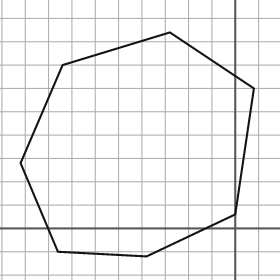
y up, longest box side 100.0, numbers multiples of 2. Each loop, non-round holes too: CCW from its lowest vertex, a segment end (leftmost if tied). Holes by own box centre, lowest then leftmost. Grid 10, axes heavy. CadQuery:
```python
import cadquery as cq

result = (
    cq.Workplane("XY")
    .moveTo(-38.0, -12.0)
    .lineTo(0.0, 6.0)
    .lineTo(8.0, 60.0)
    .lineTo(-28.0, 84.0)
    .lineTo(-74.0, 70.0)
    .lineTo(-92.0, 28.0)
    .lineTo(-76.0, -10.0)
    .close()
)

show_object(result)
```